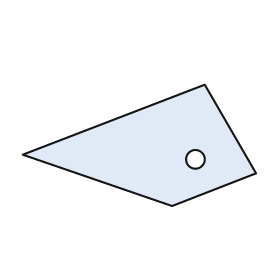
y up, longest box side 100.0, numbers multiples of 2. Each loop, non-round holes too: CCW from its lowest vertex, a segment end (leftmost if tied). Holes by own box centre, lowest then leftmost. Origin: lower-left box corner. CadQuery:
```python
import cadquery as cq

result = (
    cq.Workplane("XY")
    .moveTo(64.0, 0.0)
    .lineTo(100.0, 14.0)
    .lineTo(78.0, 52.0)
    .lineTo(0.0, 22.0)
    .close()
    .moveTo(74.0, 20.0)
    .circle(4.0)
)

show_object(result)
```